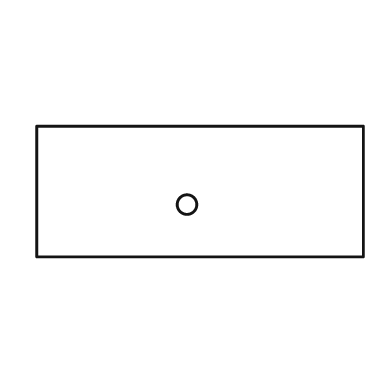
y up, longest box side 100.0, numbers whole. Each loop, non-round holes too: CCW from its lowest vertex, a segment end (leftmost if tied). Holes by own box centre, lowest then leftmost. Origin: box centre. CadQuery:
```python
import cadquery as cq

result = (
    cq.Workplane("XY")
    .moveTo(-50.0, -20.0)
    .lineTo(50.0, -20.0)
    .lineTo(50.0, 20.0)
    .lineTo(-50.0, 20.0)
    .close()
    .moveTo(-4.0, -4.0)
    .circle(3.0)
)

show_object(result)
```